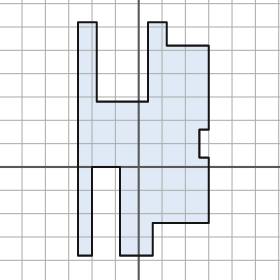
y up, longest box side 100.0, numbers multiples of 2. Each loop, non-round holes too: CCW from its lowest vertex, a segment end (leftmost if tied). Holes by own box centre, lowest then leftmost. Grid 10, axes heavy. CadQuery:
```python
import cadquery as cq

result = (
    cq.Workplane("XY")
    .moveTo(-26.0, -38.0)
    .lineTo(-20.0, -38.0)
    .lineTo(-20.0, 0.0)
    .lineTo(-8.0, 0.0)
    .lineTo(-8.0, -38.0)
    .lineTo(6.0, -38.0)
    .lineTo(6.0, -24.0)
    .lineTo(30.0, -24.0)
    .lineTo(30.0, 4.0)
    .lineTo(26.0, 4.0)
    .lineTo(26.0, 16.0)
    .lineTo(30.0, 16.0)
    .lineTo(30.0, 52.0)
    .lineTo(12.0, 52.0)
    .lineTo(12.0, 62.0)
    .lineTo(4.0, 62.0)
    .lineTo(4.0, 28.0)
    .lineTo(-18.0, 28.0)
    .lineTo(-18.0, 62.0)
    .lineTo(-26.0, 62.0)
    .close()
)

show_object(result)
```